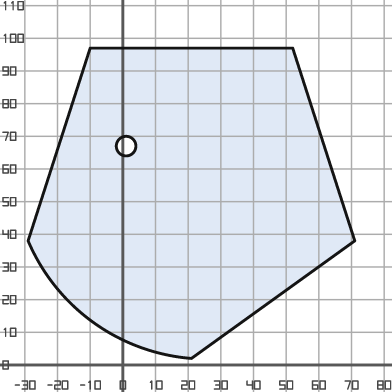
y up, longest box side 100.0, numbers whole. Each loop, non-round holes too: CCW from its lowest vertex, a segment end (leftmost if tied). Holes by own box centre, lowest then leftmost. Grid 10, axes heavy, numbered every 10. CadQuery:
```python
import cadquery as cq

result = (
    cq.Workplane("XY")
    .moveTo(21.0, 2.0)
    .lineTo(71.0, 38.0)
    .lineTo(52.0, 97.0)
    .lineTo(-10.0, 97.0)
    .lineTo(-29.0, 38.0)
    .threePointArc((-9.0, 13.0), (21.0, 2.0))
    .close()
    .moveTo(1.0, 67.0)
    .circle(3.0)
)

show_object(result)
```